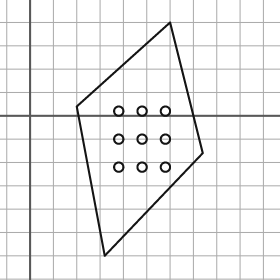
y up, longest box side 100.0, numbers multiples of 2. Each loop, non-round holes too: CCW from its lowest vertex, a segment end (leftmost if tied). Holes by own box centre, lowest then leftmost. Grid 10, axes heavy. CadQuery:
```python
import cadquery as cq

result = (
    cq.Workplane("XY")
    .moveTo(32.0, -60.0)
    .lineTo(74.0, -16.0)
    .lineTo(60.0, 40.0)
    .lineTo(20.0, 4.0)
    .close()
    .moveTo(38.0, -22.0)
    .circle(2.0)
    .moveTo(48.0, -22.0)
    .circle(2.0)
    .moveTo(58.0, -22.0)
    .circle(2.0)
    .moveTo(38.0, -10.0)
    .circle(2.0)
    .moveTo(48.0, -10.0)
    .circle(2.0)
    .moveTo(58.0, -10.0)
    .circle(2.0)
    .moveTo(38.0, 2.0)
    .circle(2.0)
    .moveTo(48.0, 2.0)
    .circle(2.0)
    .moveTo(58.0, 2.0)
    .circle(2.0)
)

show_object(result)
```